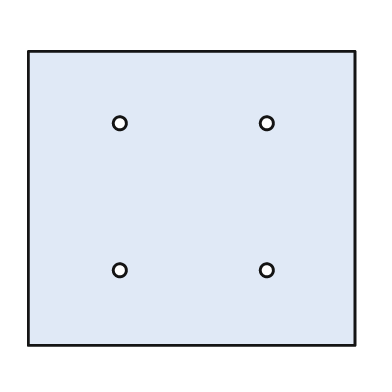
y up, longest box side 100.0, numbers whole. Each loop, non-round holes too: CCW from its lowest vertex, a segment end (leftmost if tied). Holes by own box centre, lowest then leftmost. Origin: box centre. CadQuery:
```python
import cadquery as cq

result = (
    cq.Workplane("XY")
    .moveTo(-50.0, -45.0)
    .lineTo(50.0, -45.0)
    .lineTo(50.0, 45.0)
    .lineTo(-50.0, 45.0)
    .close()
    .moveTo(-22.0, -22.0)
    .circle(2.0)
    .moveTo(23.0, -22.0)
    .circle(2.0)
    .moveTo(-22.0, 23.0)
    .circle(2.0)
    .moveTo(23.0, 23.0)
    .circle(2.0)
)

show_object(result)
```